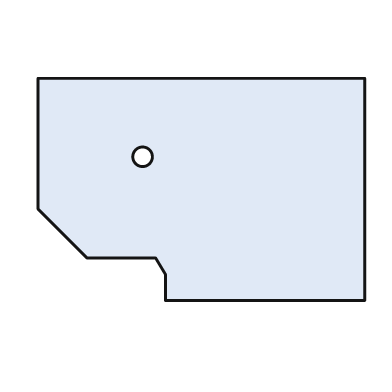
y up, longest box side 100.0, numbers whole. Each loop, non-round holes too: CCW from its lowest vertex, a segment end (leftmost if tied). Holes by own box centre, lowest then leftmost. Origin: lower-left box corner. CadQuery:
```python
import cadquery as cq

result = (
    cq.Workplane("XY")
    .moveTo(39.0, 0.0)
    .lineTo(100.0, 0.0)
    .lineTo(100.0, 68.0)
    .lineTo(0.0, 68.0)
    .lineTo(0.0, 28.0)
    .lineTo(15.0, 13.0)
    .lineTo(36.0, 13.0)
    .lineTo(39.0, 8.0)
    .close()
    .moveTo(32.0, 44.0)
    .circle(3.0)
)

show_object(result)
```